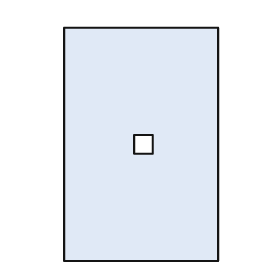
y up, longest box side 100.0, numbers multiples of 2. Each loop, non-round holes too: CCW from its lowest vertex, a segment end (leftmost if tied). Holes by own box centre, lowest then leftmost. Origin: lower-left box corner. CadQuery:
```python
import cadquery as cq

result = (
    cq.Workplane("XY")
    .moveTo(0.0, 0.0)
    .lineTo(66.0, 0.0)
    .lineTo(66.0, 100.0)
    .lineTo(0.0, 100.0)
    .close()
    .moveTo(30.0, 46.0)
    .lineTo(38.0, 46.0)
    .lineTo(38.0, 54.0)
    .lineTo(30.0, 54.0)
    .close()
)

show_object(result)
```